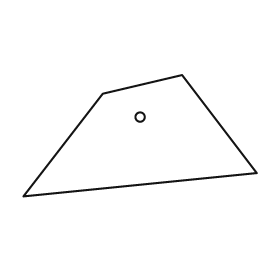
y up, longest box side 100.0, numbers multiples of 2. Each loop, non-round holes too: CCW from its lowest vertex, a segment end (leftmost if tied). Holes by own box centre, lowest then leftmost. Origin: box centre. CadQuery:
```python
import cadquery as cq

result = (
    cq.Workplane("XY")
    .moveTo(-50.0, -26.0)
    .lineTo(50.0, -16.0)
    .lineTo(18.0, 26.0)
    .lineTo(-16.0, 18.0)
    .close()
    .moveTo(0.0, 8.0)
    .circle(2.0)
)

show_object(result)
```